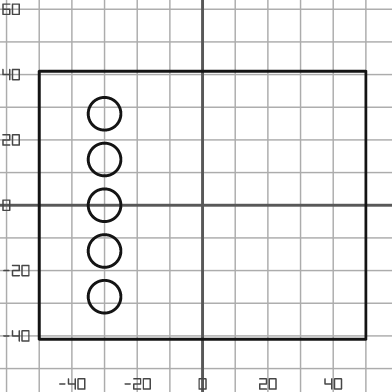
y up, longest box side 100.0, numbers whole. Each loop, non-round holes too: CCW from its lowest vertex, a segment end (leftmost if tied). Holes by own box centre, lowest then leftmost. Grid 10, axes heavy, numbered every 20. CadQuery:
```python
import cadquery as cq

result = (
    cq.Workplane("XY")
    .moveTo(-50.0, -41.0)
    .lineTo(50.0, -41.0)
    .lineTo(50.0, 41.0)
    .lineTo(-50.0, 41.0)
    .close()
    .moveTo(-30.0, -28.0)
    .circle(5.0)
    .moveTo(-30.0, -14.0)
    .circle(5.0)
    .moveTo(-30.0, 0.0)
    .circle(5.0)
    .moveTo(-30.0, 14.0)
    .circle(5.0)
    .moveTo(-30.0, 28.0)
    .circle(5.0)
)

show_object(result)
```